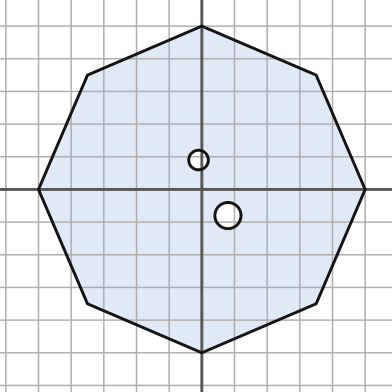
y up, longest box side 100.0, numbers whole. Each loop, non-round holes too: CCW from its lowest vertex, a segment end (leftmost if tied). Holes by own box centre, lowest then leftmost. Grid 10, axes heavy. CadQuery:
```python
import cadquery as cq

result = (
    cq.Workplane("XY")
    .moveTo(0.0, -50.0)
    .lineTo(35.0, -35.0)
    .lineTo(50.0, 0.0)
    .lineTo(35.0, 35.0)
    .lineTo(0.0, 50.0)
    .lineTo(-35.0, 35.0)
    .lineTo(-50.0, 0.0)
    .lineTo(-35.0, -35.0)
    .close()
    .moveTo(8.0, -8.0)
    .circle(4.0)
    .moveTo(-1.0, 9.0)
    .circle(3.0)
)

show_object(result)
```